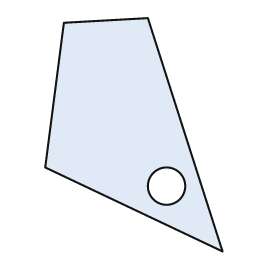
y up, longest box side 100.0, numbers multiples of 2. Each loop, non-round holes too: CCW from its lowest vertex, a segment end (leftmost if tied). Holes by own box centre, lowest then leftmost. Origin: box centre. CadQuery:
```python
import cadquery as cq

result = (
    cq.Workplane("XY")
    .moveTo(38.0, -50.0)
    .lineTo(6.0, 50.0)
    .lineTo(-30.0, 48.0)
    .lineTo(-38.0, -14.0)
    .close()
    .moveTo(14.0, -22.0)
    .circle(8.0)
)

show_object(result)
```